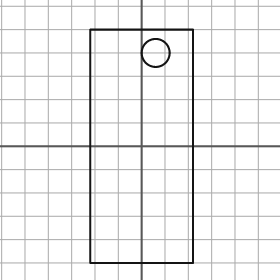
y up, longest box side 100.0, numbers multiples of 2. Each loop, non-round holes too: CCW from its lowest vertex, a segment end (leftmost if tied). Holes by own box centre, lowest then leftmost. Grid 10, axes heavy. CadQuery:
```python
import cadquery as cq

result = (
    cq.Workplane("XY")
    .moveTo(-22.0, -50.0)
    .lineTo(22.0, -50.0)
    .lineTo(22.0, 50.0)
    .lineTo(-22.0, 50.0)
    .close()
    .moveTo(6.0, 40.0)
    .circle(6.0)
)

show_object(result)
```